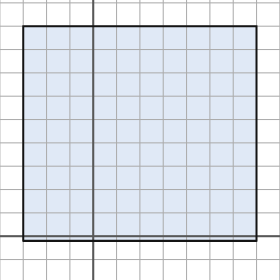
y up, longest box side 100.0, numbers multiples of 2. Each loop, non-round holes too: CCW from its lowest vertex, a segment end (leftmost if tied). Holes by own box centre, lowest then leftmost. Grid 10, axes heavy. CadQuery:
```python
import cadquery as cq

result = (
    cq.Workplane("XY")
    .moveTo(-30.0, -2.0)
    .lineTo(70.0, -2.0)
    .lineTo(70.0, 90.0)
    .lineTo(-30.0, 90.0)
    .close()
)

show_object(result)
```